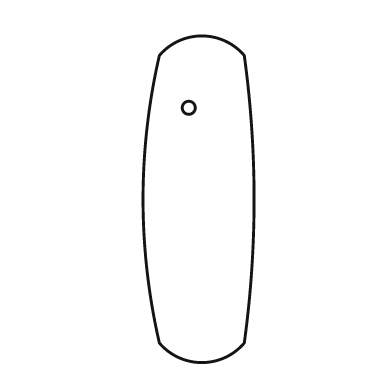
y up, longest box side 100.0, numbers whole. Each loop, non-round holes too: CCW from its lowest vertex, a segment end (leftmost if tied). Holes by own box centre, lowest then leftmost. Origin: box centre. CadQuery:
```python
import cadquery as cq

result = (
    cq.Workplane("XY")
    .moveTo(-12.0, -44.0)
    .threePointArc((1.0, -50.0), (14.0, -44.0))
    .threePointArc((17.0, 0.0), (14.0, 44.0))
    .threePointArc((1.0, 50.0), (-12.0, 44.0))
    .threePointArc((-17.0, 0.0), (-12.0, -44.0))
    .close()
    .moveTo(-3.0, 28.0)
    .circle(2.0)
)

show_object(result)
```